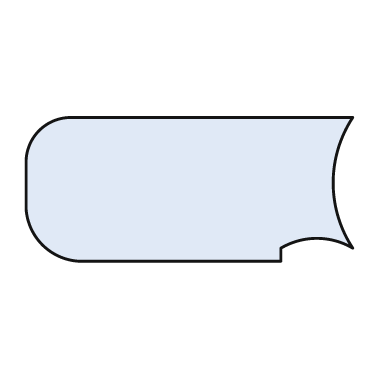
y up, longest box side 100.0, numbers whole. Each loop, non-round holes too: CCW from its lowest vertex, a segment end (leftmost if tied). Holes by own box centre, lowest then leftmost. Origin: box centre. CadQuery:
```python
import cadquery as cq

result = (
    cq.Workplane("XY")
    .moveTo(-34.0, -22.0)
    .lineTo(28.0, -22.0)
    .lineTo(28.0, -18.0)
    .threePointArc((39.0, -15.0), (50.0, -18.0))
    .threePointArc((44.0, 2.0), (50.0, 22.0))
    .lineTo(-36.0, 22.0)
    .threePointArc((-46.0, 18.0), (-50.0, 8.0))
    .lineTo(-50.0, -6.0)
    .threePointArc((-45.0, -17.0), (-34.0, -22.0))
    .close()
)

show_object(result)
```